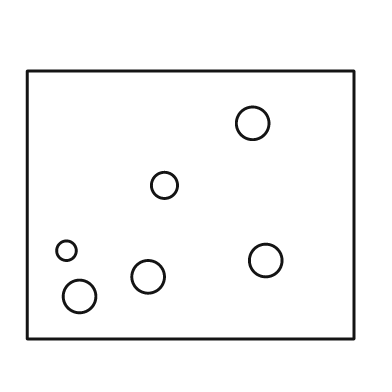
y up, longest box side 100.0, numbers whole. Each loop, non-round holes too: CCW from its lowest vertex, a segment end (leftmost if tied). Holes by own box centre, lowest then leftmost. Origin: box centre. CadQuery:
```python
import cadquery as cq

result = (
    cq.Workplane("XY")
    .moveTo(-50.0, -41.0)
    .lineTo(50.0, -41.0)
    .lineTo(50.0, 41.0)
    .lineTo(-50.0, 41.0)
    .close()
    .moveTo(-34.0, -28.0)
    .circle(5.0)
    .moveTo(-13.0, -22.0)
    .circle(5.0)
    .moveTo(23.0, -17.0)
    .circle(5.0)
    .moveTo(-38.0, -14.0)
    .circle(3.0)
    .moveTo(-8.0, 6.0)
    .circle(4.0)
    .moveTo(19.0, 25.0)
    .circle(5.0)
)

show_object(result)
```